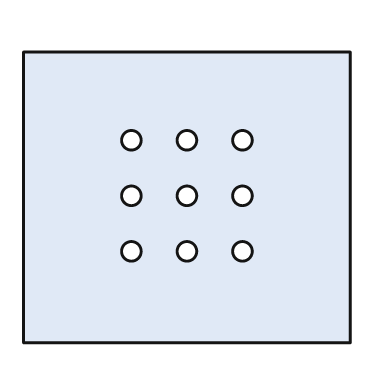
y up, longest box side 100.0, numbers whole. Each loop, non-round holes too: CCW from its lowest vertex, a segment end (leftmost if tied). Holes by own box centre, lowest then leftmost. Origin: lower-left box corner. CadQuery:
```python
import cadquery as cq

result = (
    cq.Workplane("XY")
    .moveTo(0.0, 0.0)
    .lineTo(100.0, 0.0)
    .lineTo(100.0, 89.0)
    .lineTo(0.0, 89.0)
    .close()
    .moveTo(33.0, 28.0)
    .circle(3.0)
    .moveTo(50.0, 28.0)
    .circle(3.0)
    .moveTo(67.0, 28.0)
    .circle(3.0)
    .moveTo(33.0, 45.0)
    .circle(3.0)
    .moveTo(50.0, 45.0)
    .circle(3.0)
    .moveTo(67.0, 45.0)
    .circle(3.0)
    .moveTo(33.0, 62.0)
    .circle(3.0)
    .moveTo(50.0, 62.0)
    .circle(3.0)
    .moveTo(67.0, 62.0)
    .circle(3.0)
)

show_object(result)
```